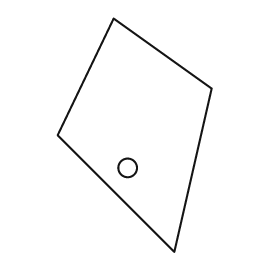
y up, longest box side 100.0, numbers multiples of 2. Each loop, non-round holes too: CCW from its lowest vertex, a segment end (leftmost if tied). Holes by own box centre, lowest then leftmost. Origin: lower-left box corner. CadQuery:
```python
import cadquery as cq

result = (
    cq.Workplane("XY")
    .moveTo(50.0, 0.0)
    .lineTo(66.0, 70.0)
    .lineTo(24.0, 100.0)
    .lineTo(0.0, 50.0)
    .close()
    .moveTo(30.0, 36.0)
    .circle(4.0)
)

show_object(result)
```